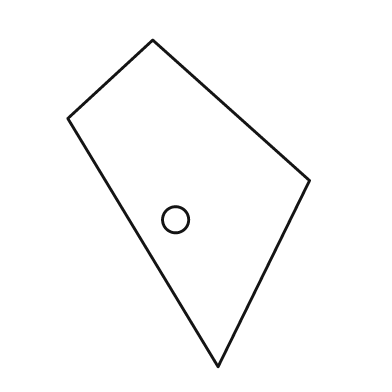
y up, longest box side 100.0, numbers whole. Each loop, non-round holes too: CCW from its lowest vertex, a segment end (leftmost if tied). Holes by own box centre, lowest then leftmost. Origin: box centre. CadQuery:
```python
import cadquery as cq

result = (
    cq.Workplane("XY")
    .moveTo(9.0, -50.0)
    .lineTo(37.0, 7.0)
    .lineTo(-11.0, 50.0)
    .lineTo(-37.0, 26.0)
    .close()
    .moveTo(-4.0, -5.0)
    .circle(4.0)
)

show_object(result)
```